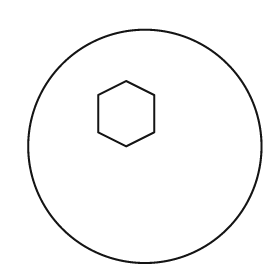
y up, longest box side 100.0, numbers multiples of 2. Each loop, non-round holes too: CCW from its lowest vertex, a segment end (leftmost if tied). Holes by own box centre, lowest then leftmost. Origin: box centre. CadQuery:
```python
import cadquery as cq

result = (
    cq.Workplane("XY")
    .moveTo(0.0, 0.0)
    .circle(50.0)
    .moveTo(-8.0, 0.0)
    .lineTo(4.0, 6.0)
    .lineTo(4.0, 22.0)
    .lineTo(-8.0, 28.0)
    .lineTo(-20.0, 22.0)
    .lineTo(-20.0, 6.0)
    .close()
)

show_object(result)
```